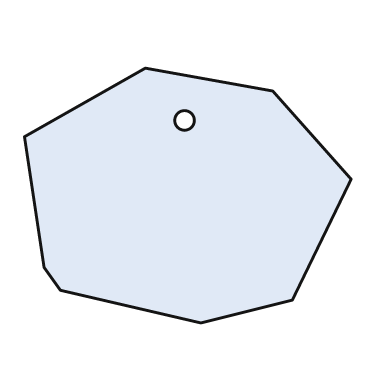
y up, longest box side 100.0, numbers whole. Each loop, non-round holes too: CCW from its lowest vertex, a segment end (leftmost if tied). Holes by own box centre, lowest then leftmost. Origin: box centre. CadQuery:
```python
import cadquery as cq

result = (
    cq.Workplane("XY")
    .moveTo(4.0, -39.0)
    .lineTo(32.0, -32.0)
    .lineTo(50.0, 5.0)
    .lineTo(26.0, 32.0)
    .lineTo(-13.0, 39.0)
    .lineTo(-50.0, 18.0)
    .lineTo(-44.0, -22.0)
    .lineTo(-39.0, -29.0)
    .close()
    .moveTo(-1.0, 23.0)
    .circle(3.0)
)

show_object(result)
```